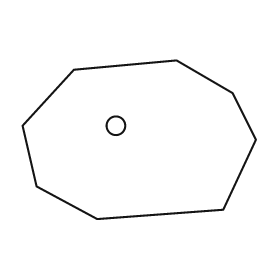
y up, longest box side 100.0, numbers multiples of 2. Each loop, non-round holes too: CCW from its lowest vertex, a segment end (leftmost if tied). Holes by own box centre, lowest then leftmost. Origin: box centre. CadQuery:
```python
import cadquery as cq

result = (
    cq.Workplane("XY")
    .moveTo(-18.0, -34.0)
    .lineTo(36.0, -30.0)
    .lineTo(50.0, 0.0)
    .lineTo(40.0, 20.0)
    .lineTo(16.0, 34.0)
    .lineTo(-28.0, 30.0)
    .lineTo(-50.0, 6.0)
    .lineTo(-44.0, -20.0)
    .close()
    .moveTo(-10.0, 6.0)
    .circle(4.0)
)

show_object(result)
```